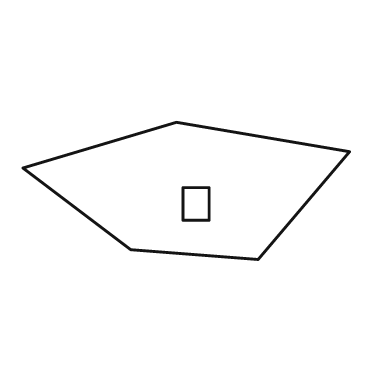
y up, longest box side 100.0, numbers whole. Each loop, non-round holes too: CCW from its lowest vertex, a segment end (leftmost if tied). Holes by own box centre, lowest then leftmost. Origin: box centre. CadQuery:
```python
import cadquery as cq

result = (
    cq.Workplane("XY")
    .moveTo(22.0, -21.0)
    .lineTo(50.0, 12.0)
    .lineTo(-3.0, 21.0)
    .lineTo(-50.0, 7.0)
    .lineTo(-17.0, -18.0)
    .close()
    .moveTo(-1.0, -9.0)
    .lineTo(7.0, -9.0)
    .lineTo(7.0, 1.0)
    .lineTo(-1.0, 1.0)
    .close()
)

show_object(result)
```